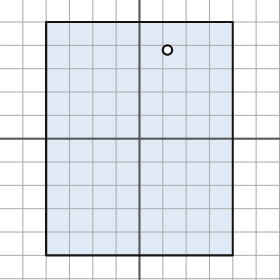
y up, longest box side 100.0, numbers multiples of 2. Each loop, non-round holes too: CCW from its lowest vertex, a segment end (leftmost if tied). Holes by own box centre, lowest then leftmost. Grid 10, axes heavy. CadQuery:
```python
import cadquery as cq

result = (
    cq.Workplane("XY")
    .moveTo(-40.0, -50.0)
    .lineTo(40.0, -50.0)
    .lineTo(40.0, 50.0)
    .lineTo(-40.0, 50.0)
    .close()
    .moveTo(12.0, 38.0)
    .circle(2.0)
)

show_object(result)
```